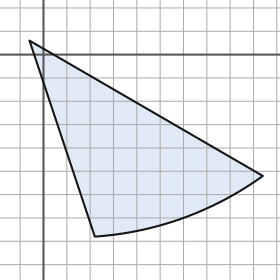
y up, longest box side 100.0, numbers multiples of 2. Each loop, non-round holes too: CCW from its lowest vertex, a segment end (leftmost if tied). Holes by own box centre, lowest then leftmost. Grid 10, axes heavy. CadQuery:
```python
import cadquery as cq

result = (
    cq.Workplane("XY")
    .moveTo(22.0, -78.0)
    .threePointArc((60.0, -70.0), (94.0, -52.0))
    .lineTo(-6.0, 6.0)
    .close()
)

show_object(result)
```